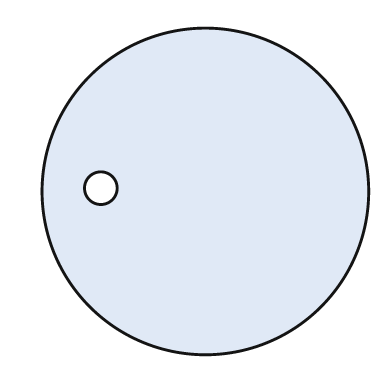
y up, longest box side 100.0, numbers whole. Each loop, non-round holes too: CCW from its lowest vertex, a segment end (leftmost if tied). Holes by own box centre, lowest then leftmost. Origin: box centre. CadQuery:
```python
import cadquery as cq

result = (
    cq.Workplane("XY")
    .moveTo(0.0, 0.0)
    .circle(50.0)
    .moveTo(-32.0, 1.0)
    .circle(5.0)
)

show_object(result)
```